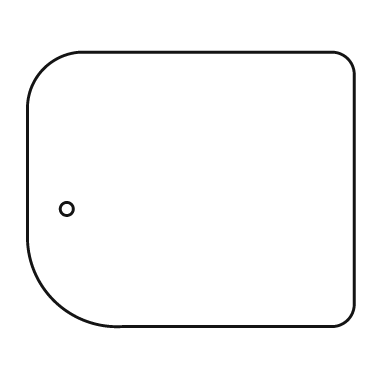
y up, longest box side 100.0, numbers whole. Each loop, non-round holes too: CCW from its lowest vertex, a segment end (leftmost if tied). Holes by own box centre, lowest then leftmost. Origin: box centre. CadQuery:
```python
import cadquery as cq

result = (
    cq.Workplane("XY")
    .moveTo(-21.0, -42.0)
    .lineTo(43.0, -42.0)
    .threePointArc((48.0, -40.0), (50.0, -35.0))
    .lineTo(50.0, 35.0)
    .threePointArc((48.0, 40.0), (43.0, 42.0))
    .lineTo(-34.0, 42.0)
    .threePointArc((-45.0, 37.0), (-50.0, 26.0))
    .lineTo(-50.0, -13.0)
    .threePointArc((-42.0, -34.0), (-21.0, -42.0))
    .close()
    .moveTo(-38.0, -6.0)
    .circle(2.0)
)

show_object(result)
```